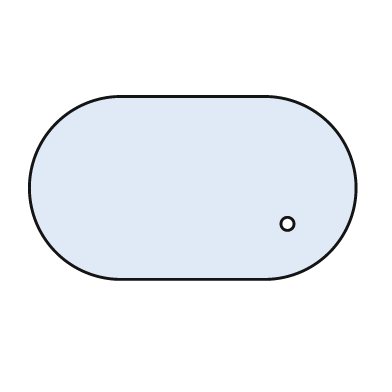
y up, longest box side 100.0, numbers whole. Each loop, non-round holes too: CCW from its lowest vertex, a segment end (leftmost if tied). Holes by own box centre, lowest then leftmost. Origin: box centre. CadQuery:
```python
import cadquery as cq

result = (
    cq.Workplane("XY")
    .moveTo(-22.0, -28.0)
    .lineTo(22.0, -28.0)
    .threePointArc((50.0, 0.0), (22.0, 28.0))
    .lineTo(-22.0, 28.0)
    .threePointArc((-50.0, 0.0), (-22.0, -28.0))
    .close()
    .moveTo(29.0, -11.0)
    .circle(2.0)
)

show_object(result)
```